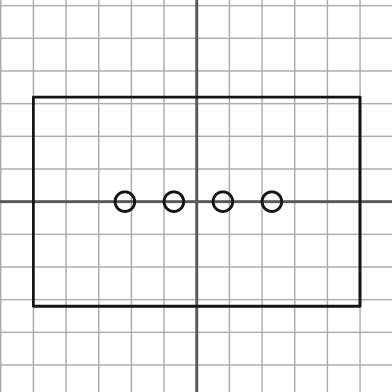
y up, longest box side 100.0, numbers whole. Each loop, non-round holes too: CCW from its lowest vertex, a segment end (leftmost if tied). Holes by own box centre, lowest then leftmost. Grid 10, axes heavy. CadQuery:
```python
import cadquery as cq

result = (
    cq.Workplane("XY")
    .moveTo(-50.0, -32.0)
    .lineTo(50.0, -32.0)
    .lineTo(50.0, 32.0)
    .lineTo(-50.0, 32.0)
    .close()
    .moveTo(-22.0, 0.0)
    .circle(3.0)
    .moveTo(-7.0, 0.0)
    .circle(3.0)
    .moveTo(8.0, 0.0)
    .circle(3.0)
    .moveTo(23.0, 0.0)
    .circle(3.0)
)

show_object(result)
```